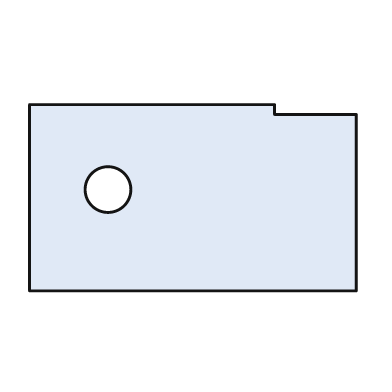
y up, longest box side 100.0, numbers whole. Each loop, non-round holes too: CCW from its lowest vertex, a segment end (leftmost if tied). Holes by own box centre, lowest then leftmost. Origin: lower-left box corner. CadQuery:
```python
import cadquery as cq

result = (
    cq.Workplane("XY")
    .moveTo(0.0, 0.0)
    .lineTo(100.0, 0.0)
    .lineTo(100.0, 54.0)
    .lineTo(75.0, 54.0)
    .lineTo(75.0, 57.0)
    .lineTo(0.0, 57.0)
    .close()
    .moveTo(24.0, 31.0)
    .circle(7.0)
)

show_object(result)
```